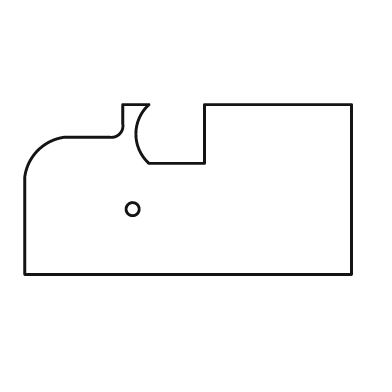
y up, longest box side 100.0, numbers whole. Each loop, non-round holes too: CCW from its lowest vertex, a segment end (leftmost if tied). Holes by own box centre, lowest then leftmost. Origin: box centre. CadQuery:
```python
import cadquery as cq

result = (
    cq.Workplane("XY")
    .moveTo(-50.0, -26.0)
    .lineTo(50.0, -26.0)
    .lineTo(50.0, 26.0)
    .lineTo(5.0, 26.0)
    .lineTo(5.0, 8.0)
    .lineTo(-12.0, 8.0)
    .threePointArc((-16.0, 17.0), (-12.0, 26.0))
    .lineTo(-20.0, 26.0)
    .lineTo(-20.0, 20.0)
    .threePointArc((-21.0, 17.0), (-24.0, 16.0))
    .lineTo(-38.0, 16.0)
    .threePointArc((-46.0, 12.0), (-50.0, 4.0))
    .close()
    .moveTo(-17.0, -6.0)
    .circle(2.0)
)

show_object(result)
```